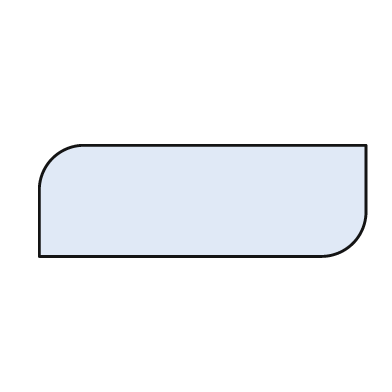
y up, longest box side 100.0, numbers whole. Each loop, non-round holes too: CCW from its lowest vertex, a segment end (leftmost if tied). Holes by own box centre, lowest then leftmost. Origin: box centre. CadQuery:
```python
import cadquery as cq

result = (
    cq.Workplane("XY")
    .moveTo(-50.0, -17.0)
    .lineTo(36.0, -17.0)
    .threePointArc((46.0, -13.0), (50.0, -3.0))
    .lineTo(50.0, 17.0)
    .lineTo(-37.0, 17.0)
    .threePointArc((-46.0, 13.0), (-50.0, 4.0))
    .close()
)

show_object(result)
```